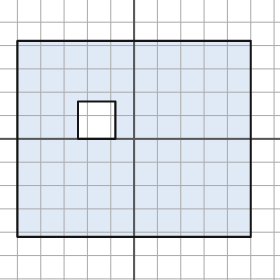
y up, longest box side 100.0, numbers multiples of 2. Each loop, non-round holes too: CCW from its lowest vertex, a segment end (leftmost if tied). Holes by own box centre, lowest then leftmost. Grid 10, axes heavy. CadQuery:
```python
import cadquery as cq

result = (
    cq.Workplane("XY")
    .moveTo(-50.0, -42.0)
    .lineTo(50.0, -42.0)
    .lineTo(50.0, 42.0)
    .lineTo(-50.0, 42.0)
    .close()
    .moveTo(-24.0, 0.0)
    .lineTo(-8.0, 0.0)
    .lineTo(-8.0, 16.0)
    .lineTo(-24.0, 16.0)
    .close()
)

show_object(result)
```